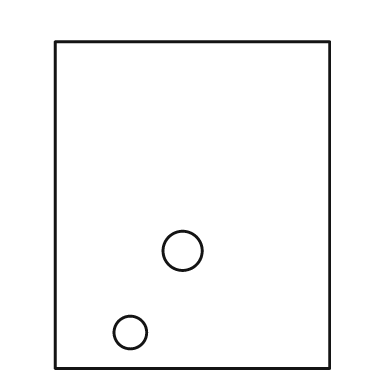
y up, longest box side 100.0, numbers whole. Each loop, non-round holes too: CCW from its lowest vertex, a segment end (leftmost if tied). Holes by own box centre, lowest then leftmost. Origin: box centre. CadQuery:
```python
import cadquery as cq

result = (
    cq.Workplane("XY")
    .moveTo(-42.0, -50.0)
    .lineTo(42.0, -50.0)
    .lineTo(42.0, 50.0)
    .lineTo(-42.0, 50.0)
    .close()
    .moveTo(-19.0, -39.0)
    .circle(5.0)
    .moveTo(-3.0, -14.0)
    .circle(6.0)
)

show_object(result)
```